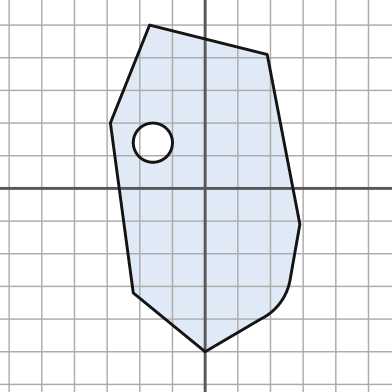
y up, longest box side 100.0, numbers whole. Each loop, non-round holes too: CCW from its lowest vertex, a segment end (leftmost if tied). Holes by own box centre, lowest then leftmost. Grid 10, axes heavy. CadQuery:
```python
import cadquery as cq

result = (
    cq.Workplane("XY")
    .moveTo(0.0, -50.0)
    .lineTo(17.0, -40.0)
    .threePointArc((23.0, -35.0), (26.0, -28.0))
    .lineTo(29.0, -11.0)
    .lineTo(19.0, 41.0)
    .lineTo(-17.0, 50.0)
    .lineTo(-29.0, 20.0)
    .lineTo(-22.0, -32.0)
    .close()
    .moveTo(-16.0, 14.0)
    .circle(6.0)
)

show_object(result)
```